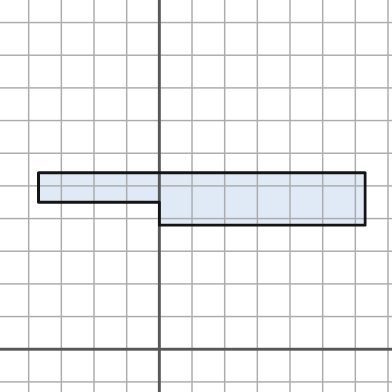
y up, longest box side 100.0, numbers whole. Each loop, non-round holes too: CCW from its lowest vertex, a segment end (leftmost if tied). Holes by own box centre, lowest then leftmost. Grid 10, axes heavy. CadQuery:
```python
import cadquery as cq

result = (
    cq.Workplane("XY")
    .moveTo(0.0, 38.0)
    .lineTo(63.0, 38.0)
    .lineTo(63.0, 54.0)
    .lineTo(-37.0, 54.0)
    .lineTo(-37.0, 45.0)
    .lineTo(0.0, 45.0)
    .close()
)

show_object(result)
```